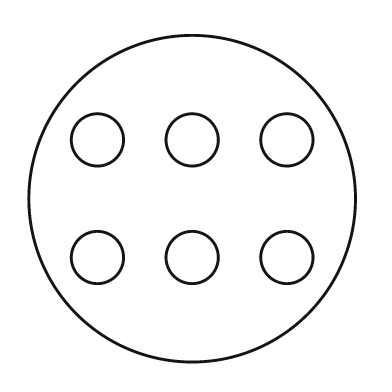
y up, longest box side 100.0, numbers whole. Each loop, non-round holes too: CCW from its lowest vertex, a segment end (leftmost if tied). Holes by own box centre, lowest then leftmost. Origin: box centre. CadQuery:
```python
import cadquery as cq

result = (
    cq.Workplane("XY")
    .moveTo(0.0, 0.0)
    .circle(50.0)
    .moveTo(-29.0, -18.0)
    .circle(8.0)
    .moveTo(0.0, -18.0)
    .circle(8.0)
    .moveTo(29.0, -18.0)
    .circle(8.0)
    .moveTo(-29.0, 18.0)
    .circle(8.0)
    .moveTo(0.0, 18.0)
    .circle(8.0)
    .moveTo(29.0, 18.0)
    .circle(8.0)
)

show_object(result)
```